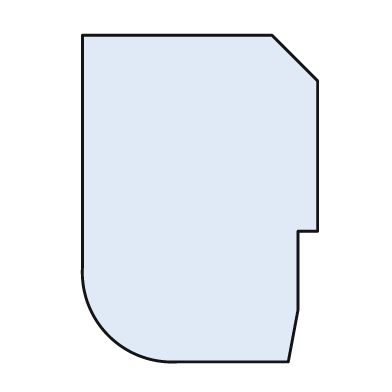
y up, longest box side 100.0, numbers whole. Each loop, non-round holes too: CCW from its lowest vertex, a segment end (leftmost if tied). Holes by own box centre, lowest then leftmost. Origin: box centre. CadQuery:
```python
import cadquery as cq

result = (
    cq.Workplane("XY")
    .moveTo(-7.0, -50.0)
    .lineTo(27.0, -50.0)
    .lineTo(30.0, -34.0)
    .lineTo(30.0, -10.0)
    .lineTo(36.0, -10.0)
    .lineTo(36.0, 36.0)
    .lineTo(22.0, 50.0)
    .lineTo(-36.0, 50.0)
    .lineTo(-36.0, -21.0)
    .threePointArc((-28.0, -42.0), (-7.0, -50.0))
    .close()
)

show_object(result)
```